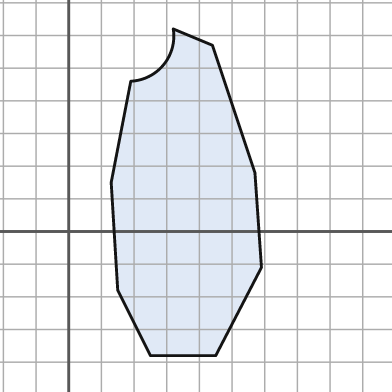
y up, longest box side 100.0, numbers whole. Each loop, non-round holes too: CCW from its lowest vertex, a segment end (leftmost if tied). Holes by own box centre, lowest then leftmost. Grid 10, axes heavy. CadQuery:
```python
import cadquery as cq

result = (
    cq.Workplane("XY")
    .moveTo(25.0, -38.0)
    .lineTo(45.0, -38.0)
    .lineTo(59.0, -11.0)
    .lineTo(57.0, 18.0)
    .lineTo(44.0, 57.0)
    .lineTo(32.0, 62.0)
    .threePointArc((29.0, 51.0), (19.0, 46.0))
    .lineTo(13.0, 15.0)
    .lineTo(15.0, -18.0)
    .close()
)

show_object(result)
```